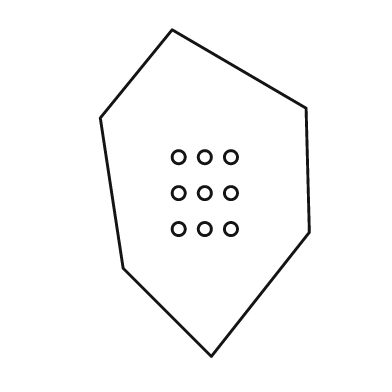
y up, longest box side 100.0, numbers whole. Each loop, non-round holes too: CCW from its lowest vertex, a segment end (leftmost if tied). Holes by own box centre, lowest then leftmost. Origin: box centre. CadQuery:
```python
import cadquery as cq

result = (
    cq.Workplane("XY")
    .moveTo(2.0, -50.0)
    .lineTo(32.0, -12.0)
    .lineTo(31.0, 26.0)
    .lineTo(-10.0, 50.0)
    .lineTo(-32.0, 23.0)
    .lineTo(-25.0, -23.0)
    .close()
    .moveTo(-8.0, -11.0)
    .circle(2.0)
    .moveTo(0.0, -11.0)
    .circle(2.0)
    .moveTo(8.0, -11.0)
    .circle(2.0)
    .moveTo(-8.0, 0.0)
    .circle(2.0)
    .moveTo(0.0, 0.0)
    .circle(2.0)
    .moveTo(8.0, 0.0)
    .circle(2.0)
    .moveTo(-8.0, 11.0)
    .circle(2.0)
    .moveTo(0.0, 11.0)
    .circle(2.0)
    .moveTo(8.0, 11.0)
    .circle(2.0)
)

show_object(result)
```